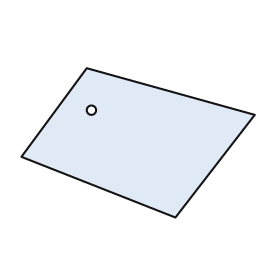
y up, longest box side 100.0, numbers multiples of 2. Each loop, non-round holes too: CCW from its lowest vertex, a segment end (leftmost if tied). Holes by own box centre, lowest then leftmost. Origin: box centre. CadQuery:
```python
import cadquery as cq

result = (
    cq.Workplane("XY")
    .moveTo(16.0, -32.0)
    .lineTo(50.0, 12.0)
    .lineTo(-22.0, 32.0)
    .lineTo(-50.0, -6.0)
    .close()
    .moveTo(-20.0, 14.0)
    .circle(2.0)
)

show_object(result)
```